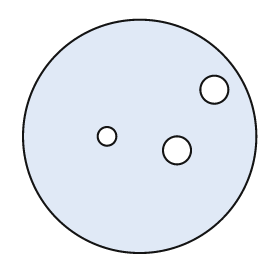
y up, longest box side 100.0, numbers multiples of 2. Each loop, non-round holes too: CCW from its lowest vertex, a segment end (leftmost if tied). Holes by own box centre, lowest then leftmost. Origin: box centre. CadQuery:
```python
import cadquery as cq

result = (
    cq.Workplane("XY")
    .moveTo(0.0, 0.0)
    .circle(50.0)
    .moveTo(16.0, -6.0)
    .circle(6.0)
    .moveTo(-14.0, 0.0)
    .circle(4.0)
    .moveTo(32.0, 20.0)
    .circle(6.0)
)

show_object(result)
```